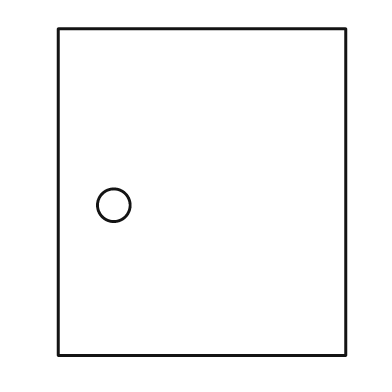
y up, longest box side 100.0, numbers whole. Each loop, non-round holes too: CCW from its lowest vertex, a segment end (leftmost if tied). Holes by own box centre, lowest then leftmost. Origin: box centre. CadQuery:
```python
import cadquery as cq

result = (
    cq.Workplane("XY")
    .moveTo(-44.0, -50.0)
    .lineTo(44.0, -50.0)
    .lineTo(44.0, 50.0)
    .lineTo(-44.0, 50.0)
    .close()
    .moveTo(-27.0, -4.0)
    .circle(5.0)
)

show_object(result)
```